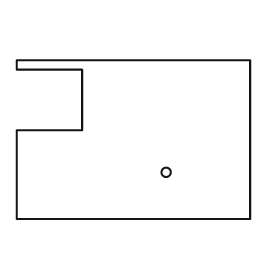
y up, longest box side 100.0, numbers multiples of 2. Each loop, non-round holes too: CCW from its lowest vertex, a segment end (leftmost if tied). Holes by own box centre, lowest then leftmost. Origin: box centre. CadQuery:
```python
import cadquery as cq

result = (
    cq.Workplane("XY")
    .moveTo(-50.0, -34.0)
    .lineTo(50.0, -34.0)
    .lineTo(50.0, 34.0)
    .lineTo(-50.0, 34.0)
    .lineTo(-50.0, 30.0)
    .lineTo(-22.0, 30.0)
    .lineTo(-22.0, 4.0)
    .lineTo(-50.0, 4.0)
    .close()
    .moveTo(14.0, -14.0)
    .circle(2.0)
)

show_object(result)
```